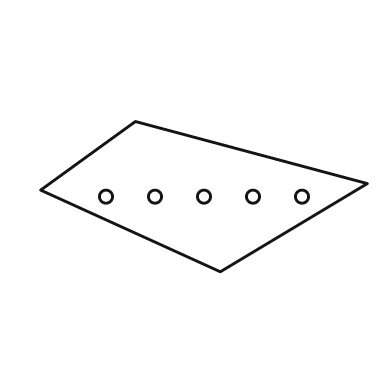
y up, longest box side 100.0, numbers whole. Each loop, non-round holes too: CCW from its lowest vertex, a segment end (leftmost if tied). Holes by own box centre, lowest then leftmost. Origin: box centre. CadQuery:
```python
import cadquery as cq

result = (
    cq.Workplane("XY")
    .moveTo(5.0, -23.0)
    .lineTo(50.0, 4.0)
    .lineTo(-21.0, 23.0)
    .lineTo(-50.0, 2.0)
    .close()
    .moveTo(-30.0, 0.0)
    .circle(2.0)
    .moveTo(-15.0, 0.0)
    .circle(2.0)
    .moveTo(0.0, 0.0)
    .circle(2.0)
    .moveTo(15.0, 0.0)
    .circle(2.0)
    .moveTo(30.0, 0.0)
    .circle(2.0)
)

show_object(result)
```